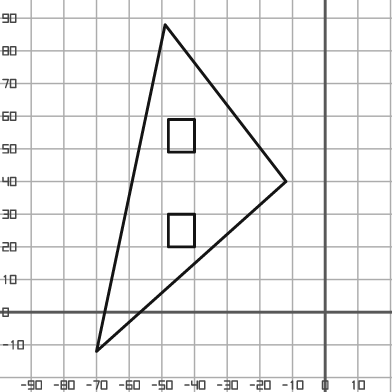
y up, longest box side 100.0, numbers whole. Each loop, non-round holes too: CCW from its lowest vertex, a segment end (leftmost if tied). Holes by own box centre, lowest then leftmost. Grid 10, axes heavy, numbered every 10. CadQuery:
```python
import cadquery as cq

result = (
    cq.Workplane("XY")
    .moveTo(-70.0, -12.0)
    .lineTo(-12.0, 40.0)
    .lineTo(-49.0, 88.0)
    .close()
    .moveTo(-48.0, 20.0)
    .lineTo(-40.0, 20.0)
    .lineTo(-40.0, 30.0)
    .lineTo(-48.0, 30.0)
    .close()
    .moveTo(-48.0, 49.0)
    .lineTo(-40.0, 49.0)
    .lineTo(-40.0, 59.0)
    .lineTo(-48.0, 59.0)
    .close()
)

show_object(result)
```